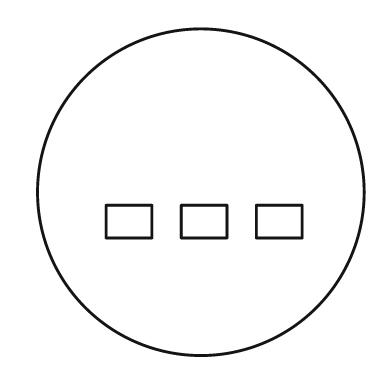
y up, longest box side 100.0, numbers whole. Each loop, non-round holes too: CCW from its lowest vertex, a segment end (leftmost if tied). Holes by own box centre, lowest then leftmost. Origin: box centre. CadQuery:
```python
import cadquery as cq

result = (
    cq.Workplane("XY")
    .moveTo(0.0, 0.0)
    .circle(50.0)
    .moveTo(-29.0, -14.0)
    .lineTo(-15.0, -14.0)
    .lineTo(-15.0, -4.0)
    .lineTo(-29.0, -4.0)
    .close()
    .moveTo(-6.0, -14.0)
    .lineTo(8.0, -14.0)
    .lineTo(8.0, -4.0)
    .lineTo(-6.0, -4.0)
    .close()
    .moveTo(17.0, -14.0)
    .lineTo(31.0, -14.0)
    .lineTo(31.0, -4.0)
    .lineTo(17.0, -4.0)
    .close()
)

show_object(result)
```